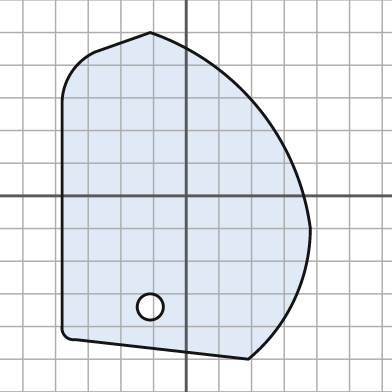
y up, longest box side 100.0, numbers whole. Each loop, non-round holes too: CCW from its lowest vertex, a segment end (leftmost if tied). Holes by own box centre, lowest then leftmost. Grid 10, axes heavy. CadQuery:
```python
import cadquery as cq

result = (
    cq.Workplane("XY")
    .moveTo(19.0, -50.0)
    .threePointArc((33.0, -32.0), (38.0, -10.0))
    .threePointArc((22.0, 27.0), (-11.0, 50.0))
    .lineTo(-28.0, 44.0)
    .threePointArc((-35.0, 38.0), (-38.0, 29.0))
    .lineTo(-38.0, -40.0)
    .threePointArc((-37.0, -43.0), (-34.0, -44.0))
    .close()
    .moveTo(-11.0, -34.0)
    .circle(4.0)
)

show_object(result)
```